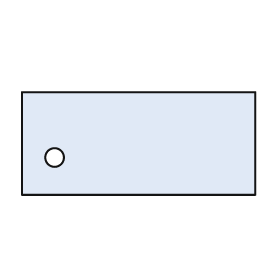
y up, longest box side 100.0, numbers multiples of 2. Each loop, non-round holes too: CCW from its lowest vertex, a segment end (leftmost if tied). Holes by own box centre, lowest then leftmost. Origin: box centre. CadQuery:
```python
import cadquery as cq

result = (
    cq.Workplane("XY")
    .moveTo(-50.0, -22.0)
    .lineTo(50.0, -22.0)
    .lineTo(50.0, 22.0)
    .lineTo(-50.0, 22.0)
    .close()
    .moveTo(-36.0, -6.0)
    .circle(4.0)
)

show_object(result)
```